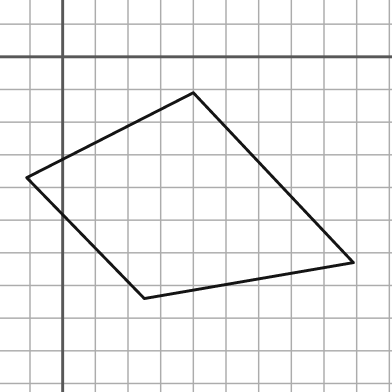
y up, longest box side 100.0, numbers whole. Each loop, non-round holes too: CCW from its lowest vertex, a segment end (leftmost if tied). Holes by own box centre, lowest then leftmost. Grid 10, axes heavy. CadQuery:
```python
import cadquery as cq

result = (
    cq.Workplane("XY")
    .moveTo(25.0, -74.0)
    .lineTo(89.0, -63.0)
    .lineTo(40.0, -11.0)
    .lineTo(-11.0, -37.0)
    .close()
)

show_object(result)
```